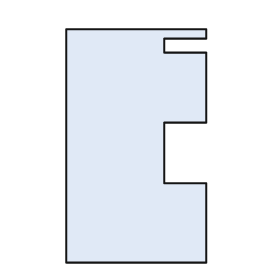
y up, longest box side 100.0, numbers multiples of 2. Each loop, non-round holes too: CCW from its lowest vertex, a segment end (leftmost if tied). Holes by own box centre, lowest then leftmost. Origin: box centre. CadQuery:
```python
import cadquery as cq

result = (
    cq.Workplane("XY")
    .moveTo(-30.0, -50.0)
    .lineTo(30.0, -50.0)
    .lineTo(30.0, -16.0)
    .lineTo(12.0, -16.0)
    .lineTo(12.0, 10.0)
    .lineTo(30.0, 10.0)
    .lineTo(30.0, 40.0)
    .lineTo(12.0, 40.0)
    .lineTo(12.0, 46.0)
    .lineTo(30.0, 46.0)
    .lineTo(30.0, 50.0)
    .lineTo(-30.0, 50.0)
    .close()
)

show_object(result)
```